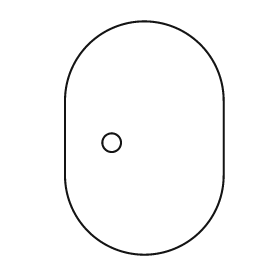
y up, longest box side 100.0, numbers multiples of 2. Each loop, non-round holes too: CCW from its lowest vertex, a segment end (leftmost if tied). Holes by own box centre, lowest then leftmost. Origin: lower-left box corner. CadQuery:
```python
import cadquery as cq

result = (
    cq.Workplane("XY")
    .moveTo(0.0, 34.0)
    .threePointArc((34.0, 0.0), (68.0, 34.0))
    .lineTo(68.0, 66.0)
    .threePointArc((34.0, 100.0), (0.0, 66.0))
    .close()
    .moveTo(20.0, 48.0)
    .circle(4.0)
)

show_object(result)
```